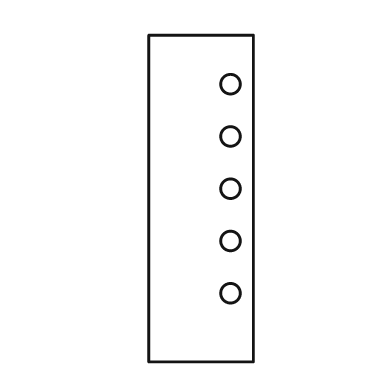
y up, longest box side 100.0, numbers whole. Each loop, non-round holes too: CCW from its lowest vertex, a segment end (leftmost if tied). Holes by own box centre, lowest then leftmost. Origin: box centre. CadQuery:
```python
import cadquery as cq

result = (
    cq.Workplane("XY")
    .moveTo(-16.0, -50.0)
    .lineTo(16.0, -50.0)
    .lineTo(16.0, 50.0)
    .lineTo(-16.0, 50.0)
    .close()
    .moveTo(9.0, -29.0)
    .circle(3.0)
    .moveTo(9.0, -13.0)
    .circle(3.0)
    .moveTo(9.0, 3.0)
    .circle(3.0)
    .moveTo(9.0, 19.0)
    .circle(3.0)
    .moveTo(9.0, 35.0)
    .circle(3.0)
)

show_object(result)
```